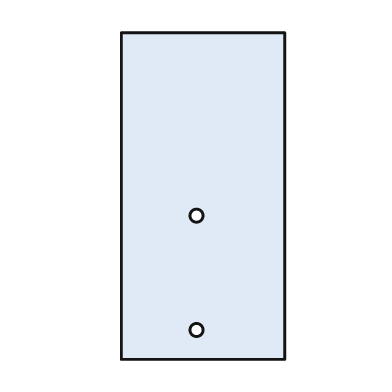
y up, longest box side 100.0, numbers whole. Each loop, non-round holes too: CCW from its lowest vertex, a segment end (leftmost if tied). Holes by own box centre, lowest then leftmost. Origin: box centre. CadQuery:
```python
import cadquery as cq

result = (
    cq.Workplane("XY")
    .moveTo(-25.0, -50.0)
    .lineTo(25.0, -50.0)
    .lineTo(25.0, 50.0)
    .lineTo(-25.0, 50.0)
    .close()
    .moveTo(-2.0, -41.0)
    .circle(2.0)
    .moveTo(-2.0, -6.0)
    .circle(2.0)
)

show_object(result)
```